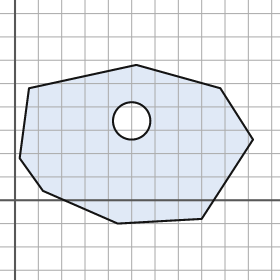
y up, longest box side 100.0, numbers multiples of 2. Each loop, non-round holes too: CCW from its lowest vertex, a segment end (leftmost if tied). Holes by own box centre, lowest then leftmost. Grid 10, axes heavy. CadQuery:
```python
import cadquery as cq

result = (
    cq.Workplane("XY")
    .moveTo(44.0, -10.0)
    .lineTo(80.0, -8.0)
    .lineTo(102.0, 26.0)
    .lineTo(88.0, 48.0)
    .lineTo(52.0, 58.0)
    .lineTo(6.0, 48.0)
    .lineTo(2.0, 18.0)
    .lineTo(12.0, 4.0)
    .close()
    .moveTo(50.0, 34.0)
    .circle(8.0)
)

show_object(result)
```